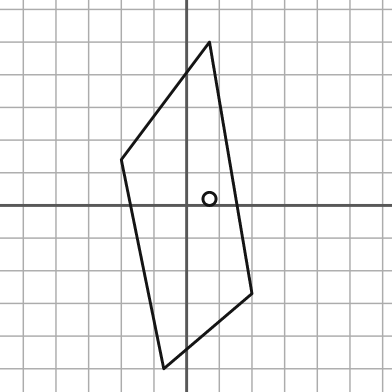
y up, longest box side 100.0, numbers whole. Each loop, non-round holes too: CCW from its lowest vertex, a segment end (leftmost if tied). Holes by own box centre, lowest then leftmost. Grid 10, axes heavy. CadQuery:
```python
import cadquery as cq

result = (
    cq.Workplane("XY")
    .moveTo(-7.0, -50.0)
    .lineTo(20.0, -27.0)
    .lineTo(7.0, 50.0)
    .lineTo(-20.0, 14.0)
    .close()
    .moveTo(7.0, 2.0)
    .circle(2.0)
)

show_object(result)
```